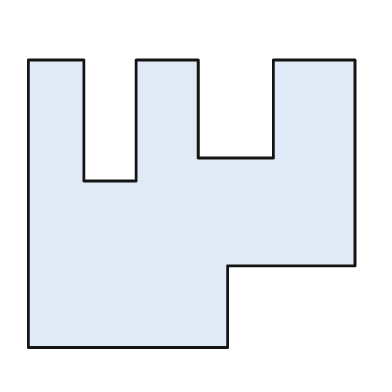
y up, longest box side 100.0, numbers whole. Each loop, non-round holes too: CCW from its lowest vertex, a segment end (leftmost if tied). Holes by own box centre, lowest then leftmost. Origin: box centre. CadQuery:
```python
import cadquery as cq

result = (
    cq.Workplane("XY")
    .moveTo(-50.0, -44.0)
    .lineTo(11.0, -44.0)
    .lineTo(11.0, -19.0)
    .lineTo(50.0, -19.0)
    .lineTo(50.0, 44.0)
    .lineTo(25.0, 44.0)
    .lineTo(25.0, 14.0)
    .lineTo(2.0, 14.0)
    .lineTo(2.0, 44.0)
    .lineTo(-17.0, 44.0)
    .lineTo(-17.0, 7.0)
    .lineTo(-33.0, 7.0)
    .lineTo(-33.0, 44.0)
    .lineTo(-50.0, 44.0)
    .close()
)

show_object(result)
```